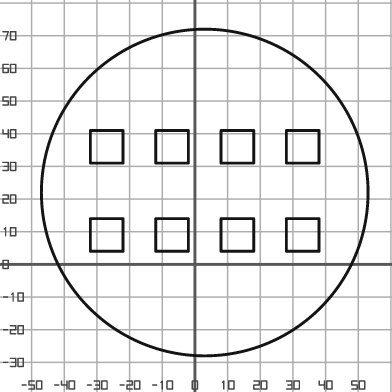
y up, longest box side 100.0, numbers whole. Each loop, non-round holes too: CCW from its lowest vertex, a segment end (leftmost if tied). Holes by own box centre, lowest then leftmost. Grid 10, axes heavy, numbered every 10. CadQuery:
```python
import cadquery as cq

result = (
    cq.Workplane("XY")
    .moveTo(3.0, 22.0)
    .circle(50.0)
    .moveTo(-32.0, 4.0)
    .lineTo(-22.0, 4.0)
    .lineTo(-22.0, 14.0)
    .lineTo(-32.0, 14.0)
    .close()
    .moveTo(-12.0, 4.0)
    .lineTo(-2.0, 4.0)
    .lineTo(-2.0, 14.0)
    .lineTo(-12.0, 14.0)
    .close()
    .moveTo(8.0, 4.0)
    .lineTo(18.0, 4.0)
    .lineTo(18.0, 14.0)
    .lineTo(8.0, 14.0)
    .close()
    .moveTo(28.0, 4.0)
    .lineTo(38.0, 4.0)
    .lineTo(38.0, 14.0)
    .lineTo(28.0, 14.0)
    .close()
    .moveTo(-32.0, 31.0)
    .lineTo(-22.0, 31.0)
    .lineTo(-22.0, 41.0)
    .lineTo(-32.0, 41.0)
    .close()
    .moveTo(-12.0, 31.0)
    .lineTo(-2.0, 31.0)
    .lineTo(-2.0, 41.0)
    .lineTo(-12.0, 41.0)
    .close()
    .moveTo(8.0, 31.0)
    .lineTo(18.0, 31.0)
    .lineTo(18.0, 41.0)
    .lineTo(8.0, 41.0)
    .close()
    .moveTo(28.0, 31.0)
    .lineTo(38.0, 31.0)
    .lineTo(38.0, 41.0)
    .lineTo(28.0, 41.0)
    .close()
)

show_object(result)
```